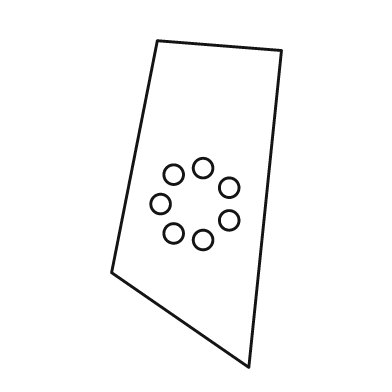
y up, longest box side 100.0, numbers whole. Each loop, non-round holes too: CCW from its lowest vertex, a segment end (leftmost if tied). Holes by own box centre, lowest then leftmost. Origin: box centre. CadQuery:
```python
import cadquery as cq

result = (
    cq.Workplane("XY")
    .moveTo(16.0, -50.0)
    .lineTo(26.0, 47.0)
    .lineTo(-12.0, 50.0)
    .lineTo(-26.0, -21.0)
    .close()
    .moveTo(2.0, -11.0)
    .circle(3.0)
    .moveTo(-7.0, -9.0)
    .circle(3.0)
    .moveTo(10.0, -5.0)
    .circle(3.0)
    .moveTo(-11.0, 0.0)
    .circle(3.0)
    .moveTo(10.0, 5.0)
    .circle(3.0)
    .moveTo(-7.0, 9.0)
    .circle(3.0)
    .moveTo(2.0, 11.0)
    .circle(3.0)
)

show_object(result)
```